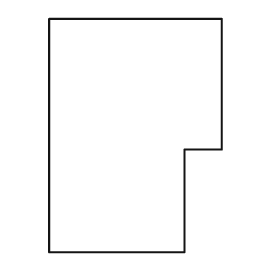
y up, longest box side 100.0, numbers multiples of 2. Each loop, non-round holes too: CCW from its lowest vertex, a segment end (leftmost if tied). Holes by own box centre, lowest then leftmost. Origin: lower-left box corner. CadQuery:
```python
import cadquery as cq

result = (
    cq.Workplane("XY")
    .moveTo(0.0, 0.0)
    .lineTo(58.0, 0.0)
    .lineTo(58.0, 44.0)
    .lineTo(74.0, 44.0)
    .lineTo(74.0, 100.0)
    .lineTo(0.0, 100.0)
    .close()
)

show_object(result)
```